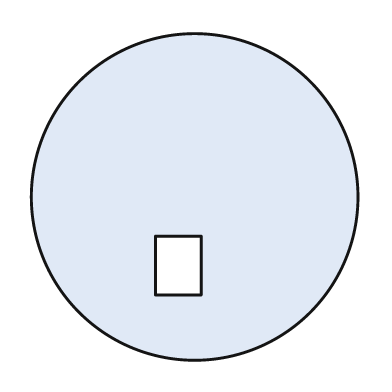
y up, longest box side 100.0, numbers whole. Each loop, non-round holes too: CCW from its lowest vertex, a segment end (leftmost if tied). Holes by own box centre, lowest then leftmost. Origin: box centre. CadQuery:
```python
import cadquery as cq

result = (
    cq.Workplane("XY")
    .moveTo(0.0, 0.0)
    .circle(50.0)
    .moveTo(-12.0, -30.0)
    .lineTo(2.0, -30.0)
    .lineTo(2.0, -12.0)
    .lineTo(-12.0, -12.0)
    .close()
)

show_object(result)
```